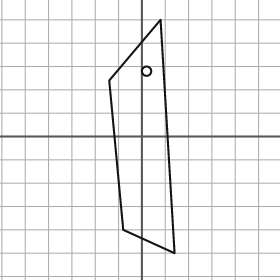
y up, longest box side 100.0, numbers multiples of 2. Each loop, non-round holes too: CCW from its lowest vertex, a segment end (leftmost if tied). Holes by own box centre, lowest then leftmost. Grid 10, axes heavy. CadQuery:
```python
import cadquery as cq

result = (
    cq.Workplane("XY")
    .moveTo(14.0, -50.0)
    .lineTo(8.0, 50.0)
    .lineTo(-14.0, 24.0)
    .lineTo(-8.0, -40.0)
    .close()
    .moveTo(2.0, 28.0)
    .circle(2.0)
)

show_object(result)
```